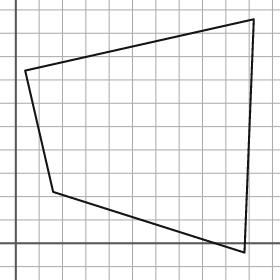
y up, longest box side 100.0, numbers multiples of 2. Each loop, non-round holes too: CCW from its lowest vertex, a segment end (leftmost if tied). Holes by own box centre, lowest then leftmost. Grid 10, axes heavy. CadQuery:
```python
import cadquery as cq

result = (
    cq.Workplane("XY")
    .moveTo(98.0, -4.0)
    .lineTo(102.0, 96.0)
    .lineTo(4.0, 74.0)
    .lineTo(16.0, 22.0)
    .close()
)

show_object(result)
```